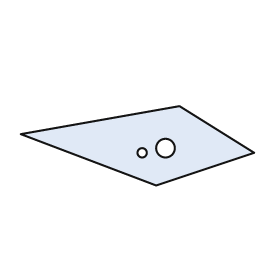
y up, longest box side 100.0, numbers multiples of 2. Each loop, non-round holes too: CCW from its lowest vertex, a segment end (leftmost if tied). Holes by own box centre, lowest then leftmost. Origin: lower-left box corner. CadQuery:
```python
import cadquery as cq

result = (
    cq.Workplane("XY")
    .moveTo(58.0, 0.0)
    .lineTo(100.0, 14.0)
    .lineTo(68.0, 34.0)
    .lineTo(0.0, 22.0)
    .close()
    .moveTo(52.0, 14.0)
    .circle(2.0)
    .moveTo(62.0, 16.0)
    .circle(4.0)
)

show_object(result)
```